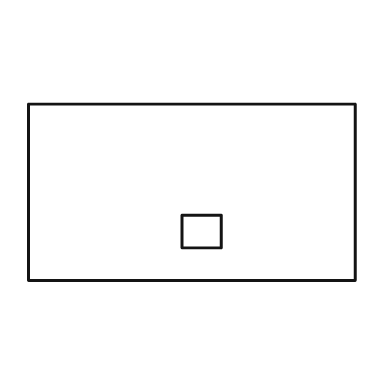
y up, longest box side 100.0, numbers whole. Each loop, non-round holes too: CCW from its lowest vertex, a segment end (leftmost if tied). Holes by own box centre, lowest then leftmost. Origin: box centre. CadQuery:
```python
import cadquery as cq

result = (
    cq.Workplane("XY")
    .moveTo(-50.0, -27.0)
    .lineTo(50.0, -27.0)
    .lineTo(50.0, 27.0)
    .lineTo(-50.0, 27.0)
    .close()
    .moveTo(-3.0, -17.0)
    .lineTo(9.0, -17.0)
    .lineTo(9.0, -7.0)
    .lineTo(-3.0, -7.0)
    .close()
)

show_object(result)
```